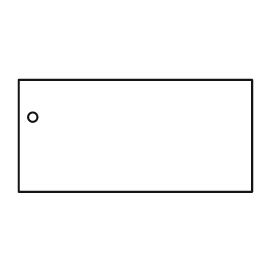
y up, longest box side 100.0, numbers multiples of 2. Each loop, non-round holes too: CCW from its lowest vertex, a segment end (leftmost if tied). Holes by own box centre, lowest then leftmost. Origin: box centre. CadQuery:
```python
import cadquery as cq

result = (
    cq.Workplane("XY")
    .moveTo(-50.0, -24.0)
    .lineTo(50.0, -24.0)
    .lineTo(50.0, 24.0)
    .lineTo(-50.0, 24.0)
    .close()
    .moveTo(-44.0, 8.0)
    .circle(2.0)
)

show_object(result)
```